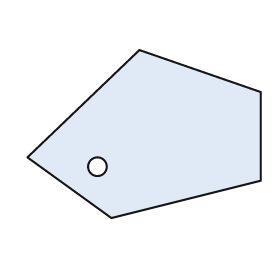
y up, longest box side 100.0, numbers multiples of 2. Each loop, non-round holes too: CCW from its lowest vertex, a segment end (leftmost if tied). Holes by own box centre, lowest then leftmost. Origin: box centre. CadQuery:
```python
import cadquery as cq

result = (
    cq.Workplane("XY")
    .moveTo(-14.0, -36.0)
    .lineTo(50.0, -20.0)
    .lineTo(50.0, 18.0)
    .lineTo(-2.0, 36.0)
    .lineTo(-50.0, -10.0)
    .close()
    .moveTo(-20.0, -14.0)
    .circle(4.0)
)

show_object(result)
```